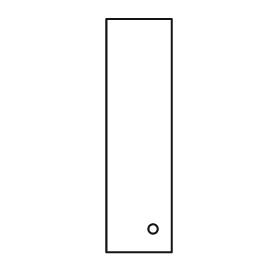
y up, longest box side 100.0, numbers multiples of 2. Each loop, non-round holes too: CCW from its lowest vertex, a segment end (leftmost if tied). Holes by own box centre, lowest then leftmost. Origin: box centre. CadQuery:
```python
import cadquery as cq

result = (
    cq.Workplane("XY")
    .moveTo(-14.0, -50.0)
    .lineTo(14.0, -50.0)
    .lineTo(14.0, 50.0)
    .lineTo(-14.0, 50.0)
    .close()
    .moveTo(6.0, -40.0)
    .circle(2.0)
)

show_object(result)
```